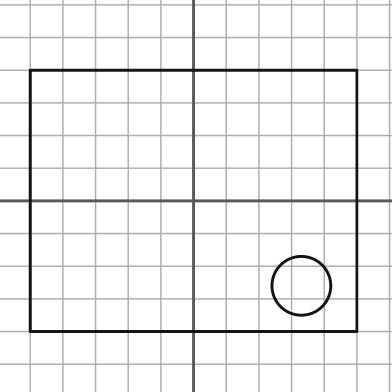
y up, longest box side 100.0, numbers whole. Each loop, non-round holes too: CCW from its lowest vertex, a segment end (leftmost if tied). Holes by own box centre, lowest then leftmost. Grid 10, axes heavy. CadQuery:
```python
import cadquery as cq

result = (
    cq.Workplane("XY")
    .moveTo(-50.0, -40.0)
    .lineTo(50.0, -40.0)
    .lineTo(50.0, 40.0)
    .lineTo(-50.0, 40.0)
    .close()
    .moveTo(33.0, -26.0)
    .circle(9.0)
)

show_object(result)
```